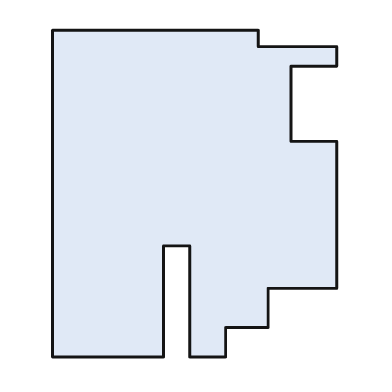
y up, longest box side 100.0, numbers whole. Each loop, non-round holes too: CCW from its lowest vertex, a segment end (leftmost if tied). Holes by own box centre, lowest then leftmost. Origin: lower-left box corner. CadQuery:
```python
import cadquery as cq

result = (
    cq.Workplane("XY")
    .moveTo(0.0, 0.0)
    .lineTo(34.0, 0.0)
    .lineTo(34.0, 34.0)
    .lineTo(42.0, 34.0)
    .lineTo(42.0, 0.0)
    .lineTo(53.0, 0.0)
    .lineTo(53.0, 9.0)
    .lineTo(66.0, 9.0)
    .lineTo(66.0, 21.0)
    .lineTo(87.0, 21.0)
    .lineTo(87.0, 66.0)
    .lineTo(73.0, 66.0)
    .lineTo(73.0, 89.0)
    .lineTo(87.0, 89.0)
    .lineTo(87.0, 95.0)
    .lineTo(63.0, 95.0)
    .lineTo(63.0, 100.0)
    .lineTo(0.0, 100.0)
    .close()
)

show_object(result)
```